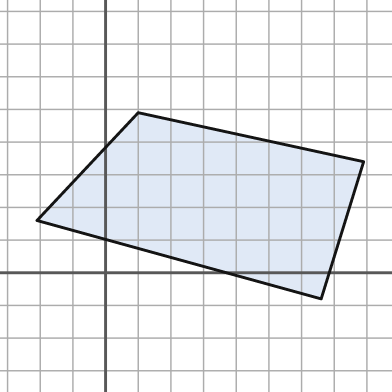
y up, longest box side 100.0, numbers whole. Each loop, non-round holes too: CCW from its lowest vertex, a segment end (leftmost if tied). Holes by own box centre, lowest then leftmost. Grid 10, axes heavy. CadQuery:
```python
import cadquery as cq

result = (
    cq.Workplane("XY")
    .moveTo(66.0, -8.0)
    .lineTo(79.0, 34.0)
    .lineTo(10.0, 49.0)
    .lineTo(-21.0, 16.0)
    .close()
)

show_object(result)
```